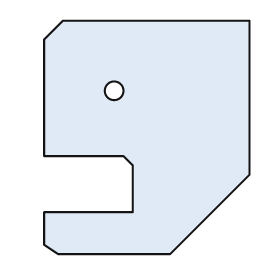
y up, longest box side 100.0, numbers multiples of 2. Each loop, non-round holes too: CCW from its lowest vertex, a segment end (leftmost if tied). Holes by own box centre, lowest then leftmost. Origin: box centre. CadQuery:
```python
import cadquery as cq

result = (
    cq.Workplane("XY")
    .moveTo(-38.0, -50.0)
    .lineTo(10.0, -50.0)
    .lineTo(44.0, -16.0)
    .lineTo(44.0, 50.0)
    .lineTo(-36.0, 50.0)
    .lineTo(-44.0, 42.0)
    .lineTo(-44.0, -8.0)
    .lineTo(-10.0, -8.0)
    .lineTo(-6.0, -12.0)
    .lineTo(-6.0, -32.0)
    .lineTo(-44.0, -32.0)
    .lineTo(-44.0, -46.0)
    .close()
    .moveTo(-14.0, 20.0)
    .circle(4.0)
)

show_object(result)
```